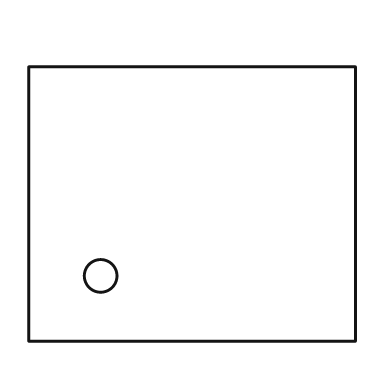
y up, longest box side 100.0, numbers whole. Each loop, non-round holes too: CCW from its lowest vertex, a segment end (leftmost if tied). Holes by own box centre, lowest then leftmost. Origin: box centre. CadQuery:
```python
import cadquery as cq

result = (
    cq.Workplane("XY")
    .moveTo(-50.0, -42.0)
    .lineTo(50.0, -42.0)
    .lineTo(50.0, 42.0)
    .lineTo(-50.0, 42.0)
    .close()
    .moveTo(-28.0, -22.0)
    .circle(5.0)
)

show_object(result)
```